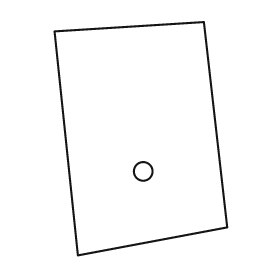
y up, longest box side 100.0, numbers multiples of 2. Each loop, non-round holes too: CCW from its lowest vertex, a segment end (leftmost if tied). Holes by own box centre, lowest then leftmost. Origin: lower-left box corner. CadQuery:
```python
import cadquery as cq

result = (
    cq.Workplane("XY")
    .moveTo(10.0, 0.0)
    .lineTo(74.0, 12.0)
    .lineTo(64.0, 100.0)
    .lineTo(0.0, 96.0)
    .close()
    .moveTo(38.0, 36.0)
    .circle(4.0)
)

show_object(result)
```